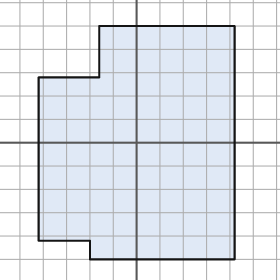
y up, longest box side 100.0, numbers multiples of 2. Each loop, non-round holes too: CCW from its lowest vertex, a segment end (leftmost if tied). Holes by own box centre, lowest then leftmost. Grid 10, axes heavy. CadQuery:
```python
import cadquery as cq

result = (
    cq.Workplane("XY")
    .moveTo(-20.0, -50.0)
    .lineTo(42.0, -50.0)
    .lineTo(42.0, 50.0)
    .lineTo(-16.0, 50.0)
    .lineTo(-16.0, 28.0)
    .lineTo(-42.0, 28.0)
    .lineTo(-42.0, -42.0)
    .lineTo(-20.0, -42.0)
    .close()
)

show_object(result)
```